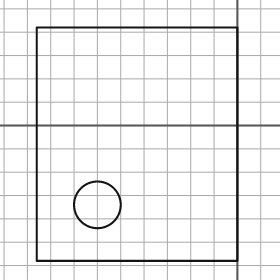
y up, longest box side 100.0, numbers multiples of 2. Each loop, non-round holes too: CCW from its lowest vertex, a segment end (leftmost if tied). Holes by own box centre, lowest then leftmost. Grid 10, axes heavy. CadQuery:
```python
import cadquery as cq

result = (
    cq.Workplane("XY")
    .moveTo(-86.0, -58.0)
    .lineTo(0.0, -58.0)
    .lineTo(0.0, 42.0)
    .lineTo(-86.0, 42.0)
    .close()
    .moveTo(-60.0, -34.0)
    .circle(10.0)
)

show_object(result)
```